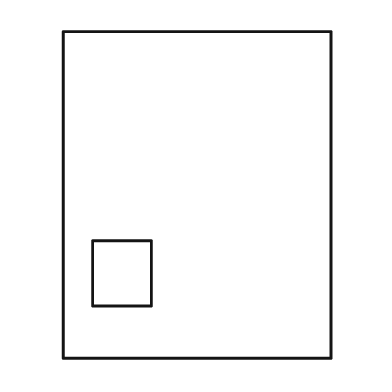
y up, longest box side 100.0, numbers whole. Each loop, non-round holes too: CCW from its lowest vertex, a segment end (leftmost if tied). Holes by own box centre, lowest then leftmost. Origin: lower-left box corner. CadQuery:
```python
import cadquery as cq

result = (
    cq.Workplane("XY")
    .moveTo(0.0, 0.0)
    .lineTo(82.0, 0.0)
    .lineTo(82.0, 100.0)
    .lineTo(0.0, 100.0)
    .close()
    .moveTo(9.0, 16.0)
    .lineTo(27.0, 16.0)
    .lineTo(27.0, 36.0)
    .lineTo(9.0, 36.0)
    .close()
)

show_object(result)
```